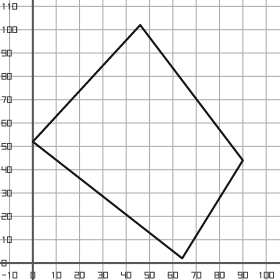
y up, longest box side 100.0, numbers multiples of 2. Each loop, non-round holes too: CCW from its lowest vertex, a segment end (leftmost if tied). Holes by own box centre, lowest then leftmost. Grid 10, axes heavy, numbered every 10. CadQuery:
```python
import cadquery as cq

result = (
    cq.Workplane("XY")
    .moveTo(64.0, 2.0)
    .lineTo(90.0, 44.0)
    .lineTo(46.0, 102.0)
    .lineTo(0.0, 52.0)
    .close()
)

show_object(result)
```